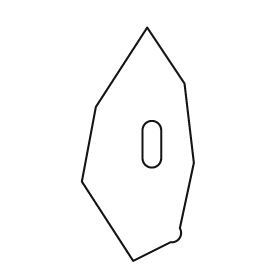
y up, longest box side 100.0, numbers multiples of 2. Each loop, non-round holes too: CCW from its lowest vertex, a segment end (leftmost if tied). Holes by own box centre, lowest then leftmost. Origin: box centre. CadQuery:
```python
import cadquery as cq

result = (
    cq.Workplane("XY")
    .moveTo(-2.0, -50.0)
    .lineTo(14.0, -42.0)
    .threePointArc((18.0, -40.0), (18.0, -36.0))
    .lineTo(24.0, -8.0)
    .lineTo(20.0, 26.0)
    .lineTo(4.0, 50.0)
    .lineTo(-18.0, 16.0)
    .lineTo(-24.0, -16.0)
    .close()
    .moveTo(2.0, -6.0)
    .threePointArc((6.0, -10.0), (10.0, -6.0))
    .lineTo(10.0, 6.0)
    .threePointArc((6.0, 10.0), (2.0, 6.0))
    .close()
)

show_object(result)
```